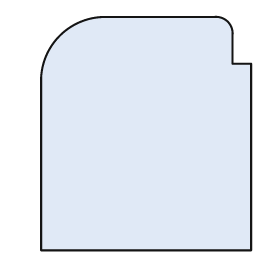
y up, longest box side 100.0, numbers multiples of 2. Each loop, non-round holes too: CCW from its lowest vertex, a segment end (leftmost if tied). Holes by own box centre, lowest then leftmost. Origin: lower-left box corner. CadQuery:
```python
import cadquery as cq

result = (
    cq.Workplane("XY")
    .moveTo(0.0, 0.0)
    .lineTo(90.0, 0.0)
    .lineTo(90.0, 80.0)
    .lineTo(82.0, 80.0)
    .lineTo(82.0, 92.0)
    .threePointArc((80.0, 98.0), (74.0, 100.0))
    .lineTo(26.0, 100.0)
    .threePointArc((8.0, 92.0), (0.0, 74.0))
    .close()
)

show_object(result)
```